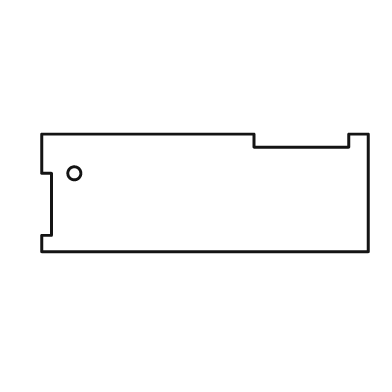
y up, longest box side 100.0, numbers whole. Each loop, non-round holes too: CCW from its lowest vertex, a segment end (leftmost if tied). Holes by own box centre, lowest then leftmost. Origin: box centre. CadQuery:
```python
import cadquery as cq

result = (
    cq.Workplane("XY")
    .moveTo(-50.0, -18.0)
    .lineTo(50.0, -18.0)
    .lineTo(50.0, 18.0)
    .lineTo(44.0, 18.0)
    .lineTo(44.0, 14.0)
    .lineTo(15.0, 14.0)
    .lineTo(15.0, 18.0)
    .lineTo(-50.0, 18.0)
    .lineTo(-50.0, 6.0)
    .lineTo(-47.0, 6.0)
    .lineTo(-47.0, -13.0)
    .lineTo(-50.0, -13.0)
    .close()
    .moveTo(-40.0, 6.0)
    .circle(2.0)
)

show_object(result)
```